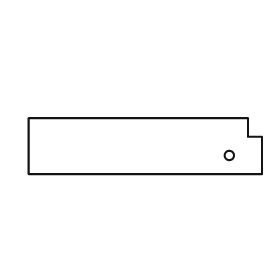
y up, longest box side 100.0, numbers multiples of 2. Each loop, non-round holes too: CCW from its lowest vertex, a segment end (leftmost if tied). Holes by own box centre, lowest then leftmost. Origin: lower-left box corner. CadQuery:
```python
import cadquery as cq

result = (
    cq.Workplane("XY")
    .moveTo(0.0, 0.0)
    .lineTo(100.0, 0.0)
    .lineTo(100.0, 16.0)
    .lineTo(94.0, 16.0)
    .lineTo(94.0, 24.0)
    .lineTo(0.0, 24.0)
    .close()
    .moveTo(86.0, 8.0)
    .circle(2.0)
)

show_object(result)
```